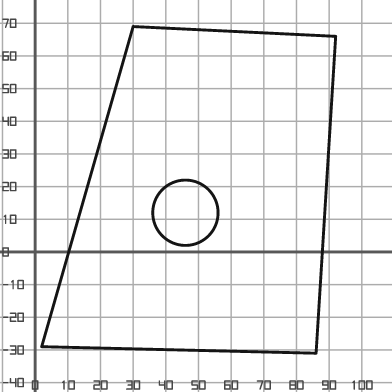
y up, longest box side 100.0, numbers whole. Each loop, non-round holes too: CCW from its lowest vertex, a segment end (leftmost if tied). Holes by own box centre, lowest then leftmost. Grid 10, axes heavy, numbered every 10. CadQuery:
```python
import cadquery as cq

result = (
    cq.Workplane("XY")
    .moveTo(86.0, -31.0)
    .lineTo(92.0, 66.0)
    .lineTo(30.0, 69.0)
    .lineTo(2.0, -29.0)
    .close()
    .moveTo(46.0, 12.0)
    .circle(10.0)
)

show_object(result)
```